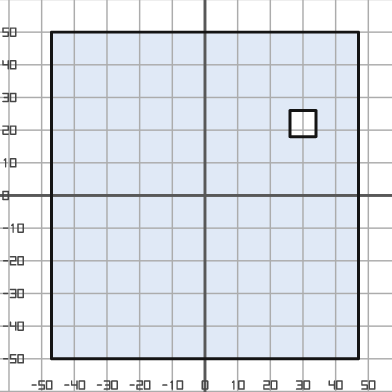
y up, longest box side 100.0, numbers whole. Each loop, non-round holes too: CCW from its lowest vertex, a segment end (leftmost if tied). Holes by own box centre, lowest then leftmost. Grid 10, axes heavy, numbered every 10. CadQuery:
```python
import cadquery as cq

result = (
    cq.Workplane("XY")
    .moveTo(-47.0, -50.0)
    .lineTo(47.0, -50.0)
    .lineTo(47.0, 50.0)
    .lineTo(-47.0, 50.0)
    .close()
    .moveTo(26.0, 18.0)
    .lineTo(34.0, 18.0)
    .lineTo(34.0, 26.0)
    .lineTo(26.0, 26.0)
    .close()
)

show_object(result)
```